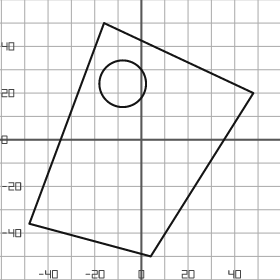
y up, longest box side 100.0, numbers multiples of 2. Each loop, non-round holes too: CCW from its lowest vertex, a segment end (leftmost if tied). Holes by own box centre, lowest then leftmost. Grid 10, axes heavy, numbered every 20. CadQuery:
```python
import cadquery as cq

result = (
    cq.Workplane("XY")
    .moveTo(4.0, -50.0)
    .lineTo(48.0, 20.0)
    .lineTo(-16.0, 50.0)
    .lineTo(-48.0, -36.0)
    .close()
    .moveTo(-8.0, 24.0)
    .circle(10.0)
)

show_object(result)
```